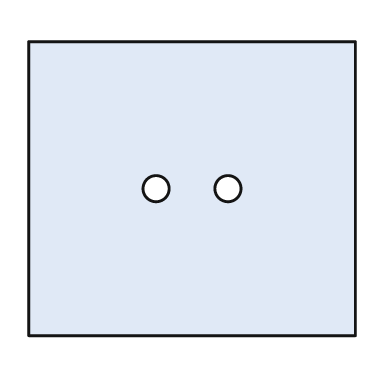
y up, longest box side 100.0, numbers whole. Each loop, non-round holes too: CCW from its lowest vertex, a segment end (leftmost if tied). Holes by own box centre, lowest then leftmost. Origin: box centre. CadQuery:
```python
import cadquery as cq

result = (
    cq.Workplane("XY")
    .moveTo(-50.0, -45.0)
    .lineTo(50.0, -45.0)
    .lineTo(50.0, 45.0)
    .lineTo(-50.0, 45.0)
    .close()
    .moveTo(-11.0, 0.0)
    .circle(4.0)
    .moveTo(11.0, 0.0)
    .circle(4.0)
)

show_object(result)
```